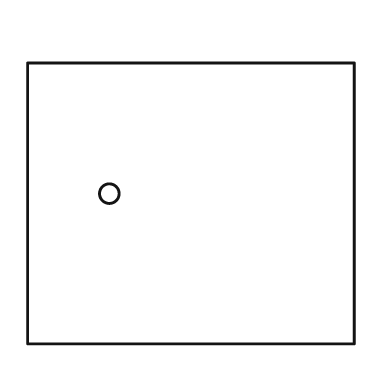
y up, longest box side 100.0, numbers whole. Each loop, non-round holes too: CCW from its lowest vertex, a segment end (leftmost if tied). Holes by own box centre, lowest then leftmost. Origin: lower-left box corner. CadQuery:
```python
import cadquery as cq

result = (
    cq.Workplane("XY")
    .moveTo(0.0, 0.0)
    .lineTo(100.0, 0.0)
    .lineTo(100.0, 86.0)
    .lineTo(0.0, 86.0)
    .close()
    .moveTo(25.0, 46.0)
    .circle(3.0)
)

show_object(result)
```